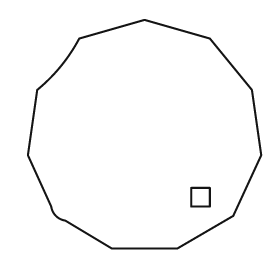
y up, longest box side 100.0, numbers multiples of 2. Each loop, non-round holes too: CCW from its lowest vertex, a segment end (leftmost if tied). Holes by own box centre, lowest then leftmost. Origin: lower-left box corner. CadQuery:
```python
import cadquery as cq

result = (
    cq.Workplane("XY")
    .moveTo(36.0, 0.0)
    .lineTo(64.0, 0.0)
    .lineTo(88.0, 14.0)
    .lineTo(100.0, 40.0)
    .lineTo(96.0, 68.0)
    .lineTo(78.0, 90.0)
    .lineTo(50.0, 98.0)
    .lineTo(22.0, 90.0)
    .threePointArc((14.0, 78.0), (4.0, 68.0))
    .lineTo(0.0, 40.0)
    .lineTo(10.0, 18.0)
    .threePointArc((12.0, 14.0), (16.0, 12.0))
    .close()
    .moveTo(70.0, 18.0)
    .lineTo(78.0, 18.0)
    .lineTo(78.0, 26.0)
    .lineTo(70.0, 26.0)
    .close()
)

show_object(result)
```